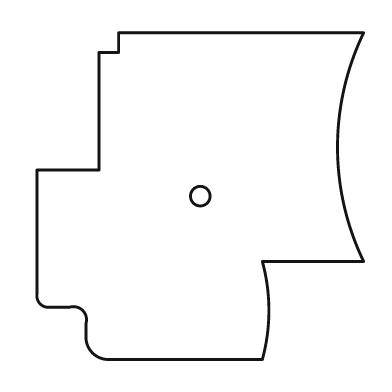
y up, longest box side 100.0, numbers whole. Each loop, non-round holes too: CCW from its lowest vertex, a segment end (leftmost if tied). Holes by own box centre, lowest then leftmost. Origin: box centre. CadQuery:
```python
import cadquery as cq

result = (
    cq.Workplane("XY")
    .moveTo(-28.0, -50.0)
    .lineTo(19.0, -50.0)
    .threePointArc((21.0, -35.0), (19.0, -20.0))
    .lineTo(50.0, -20.0)
    .threePointArc((42.0, 15.0), (50.0, 50.0))
    .lineTo(-25.0, 50.0)
    .lineTo(-25.0, 44.0)
    .lineTo(-31.0, 44.0)
    .lineTo(-31.0, 8.0)
    .lineTo(-50.0, 8.0)
    .lineTo(-50.0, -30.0)
    .threePointArc((-49.0, -33.0), (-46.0, -34.0))
    .lineTo(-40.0, -34.0)
    .threePointArc((-36.0, -35.0), (-35.0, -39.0))
    .lineTo(-35.0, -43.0)
    .threePointArc((-33.0, -48.0), (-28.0, -50.0))
    .close()
    .moveTo(0.0, 0.0)
    .circle(3.0)
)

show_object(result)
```